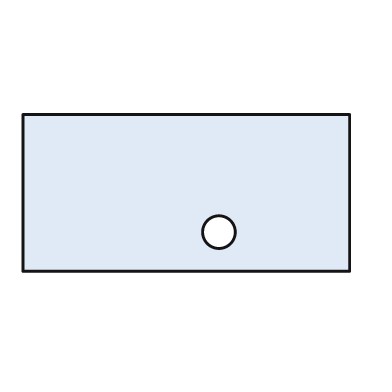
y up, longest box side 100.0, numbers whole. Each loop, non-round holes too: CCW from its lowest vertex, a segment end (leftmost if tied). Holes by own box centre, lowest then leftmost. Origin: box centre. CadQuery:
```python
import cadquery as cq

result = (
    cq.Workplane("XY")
    .moveTo(-50.0, -24.0)
    .lineTo(50.0, -24.0)
    .lineTo(50.0, 24.0)
    .lineTo(-50.0, 24.0)
    .close()
    .moveTo(10.0, -12.0)
    .circle(5.0)
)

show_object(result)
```